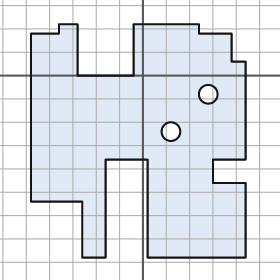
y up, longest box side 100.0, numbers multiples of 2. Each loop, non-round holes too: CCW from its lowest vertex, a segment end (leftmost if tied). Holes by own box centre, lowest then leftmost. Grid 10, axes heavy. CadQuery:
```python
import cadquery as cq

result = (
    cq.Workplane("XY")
    .moveTo(-26.0, -78.0)
    .lineTo(-16.0, -78.0)
    .lineTo(-16.0, -36.0)
    .lineTo(2.0, -36.0)
    .lineTo(2.0, -78.0)
    .lineTo(44.0, -78.0)
    .lineTo(44.0, -46.0)
    .lineTo(30.0, -46.0)
    .lineTo(30.0, -36.0)
    .lineTo(44.0, -36.0)
    .lineTo(44.0, 6.0)
    .lineTo(38.0, 6.0)
    .lineTo(38.0, 18.0)
    .lineTo(24.0, 18.0)
    .lineTo(24.0, 22.0)
    .lineTo(-4.0, 22.0)
    .lineTo(-4.0, 0.0)
    .lineTo(-28.0, 0.0)
    .lineTo(-28.0, 22.0)
    .lineTo(-36.0, 22.0)
    .lineTo(-36.0, 18.0)
    .lineTo(-48.0, 18.0)
    .lineTo(-48.0, -54.0)
    .lineTo(-26.0, -54.0)
    .close()
    .moveTo(12.0, -24.0)
    .circle(4.0)
    .moveTo(28.0, -8.0)
    .circle(4.0)
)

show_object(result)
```